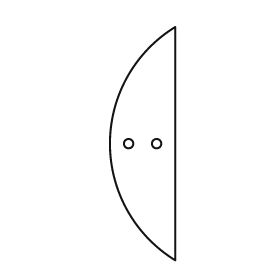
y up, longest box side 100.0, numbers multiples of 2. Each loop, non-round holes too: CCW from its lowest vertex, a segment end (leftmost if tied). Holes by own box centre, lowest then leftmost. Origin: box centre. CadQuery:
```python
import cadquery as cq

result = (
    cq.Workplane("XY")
    .moveTo(14.0, -50.0)
    .lineTo(14.0, 50.0)
    .threePointArc((-14.0, 0.0), (14.0, -50.0))
    .close()
    .moveTo(-6.0, 0.0)
    .circle(2.0)
    .moveTo(6.0, 0.0)
    .circle(2.0)
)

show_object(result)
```